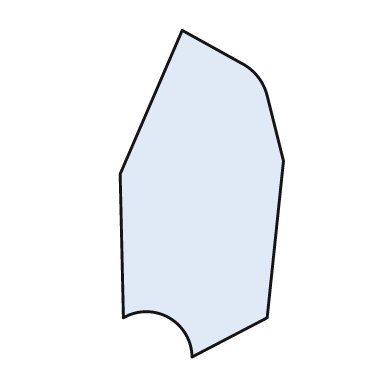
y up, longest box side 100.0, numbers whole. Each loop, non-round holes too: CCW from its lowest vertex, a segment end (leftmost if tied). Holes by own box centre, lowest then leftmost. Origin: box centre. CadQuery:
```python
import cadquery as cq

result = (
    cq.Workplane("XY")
    .moveTo(-3.0, -50.0)
    .lineTo(20.0, -38.0)
    .lineTo(25.0, 10.0)
    .lineTo(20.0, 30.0)
    .threePointArc((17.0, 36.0), (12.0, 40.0))
    .lineTo(-6.0, 50.0)
    .lineTo(-25.0, 6.0)
    .lineTo(-24.0, -38.0)
    .threePointArc((-10.0, -38.0), (-3.0, -50.0))
    .close()
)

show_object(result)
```